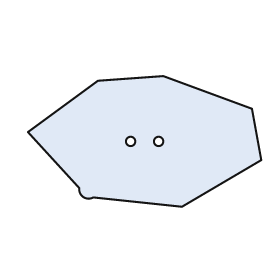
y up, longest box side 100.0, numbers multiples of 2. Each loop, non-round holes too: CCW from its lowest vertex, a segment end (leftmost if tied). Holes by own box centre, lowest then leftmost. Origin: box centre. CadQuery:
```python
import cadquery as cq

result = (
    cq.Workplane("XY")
    .moveTo(16.0, -28.0)
    .lineTo(50.0, -8.0)
    .lineTo(46.0, 14.0)
    .lineTo(8.0, 28.0)
    .lineTo(-20.0, 26.0)
    .lineTo(-50.0, 4.0)
    .lineTo(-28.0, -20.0)
    .threePointArc((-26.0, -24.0), (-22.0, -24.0))
    .close()
    .moveTo(-6.0, 0.0)
    .circle(2.0)
    .moveTo(6.0, 0.0)
    .circle(2.0)
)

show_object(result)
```